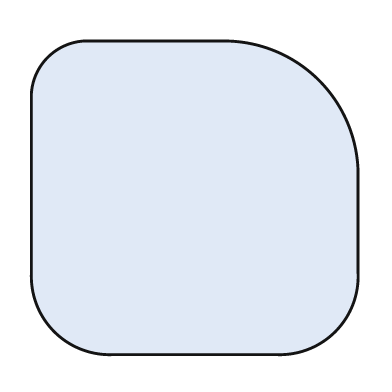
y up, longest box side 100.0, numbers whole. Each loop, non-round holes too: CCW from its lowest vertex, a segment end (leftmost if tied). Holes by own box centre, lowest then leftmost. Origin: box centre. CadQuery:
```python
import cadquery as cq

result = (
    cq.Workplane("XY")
    .moveTo(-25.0, -48.0)
    .lineTo(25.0, -48.0)
    .threePointArc((43.0, -41.0), (50.0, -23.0))
    .lineTo(50.0, 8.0)
    .threePointArc((38.0, 36.0), (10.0, 48.0))
    .lineTo(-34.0, 48.0)
    .threePointArc((-45.0, 43.0), (-50.0, 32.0))
    .lineTo(-50.0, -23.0)
    .threePointArc((-43.0, -41.0), (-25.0, -48.0))
    .close()
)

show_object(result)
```